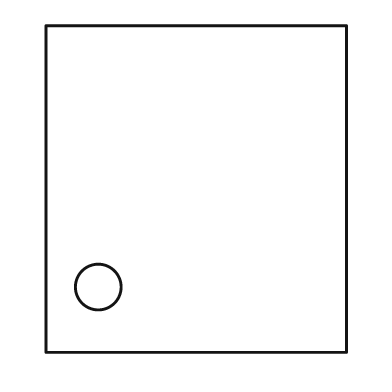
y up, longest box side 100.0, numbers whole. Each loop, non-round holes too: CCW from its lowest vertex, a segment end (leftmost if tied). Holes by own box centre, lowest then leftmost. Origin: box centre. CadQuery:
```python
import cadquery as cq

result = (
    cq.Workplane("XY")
    .moveTo(-46.0, -50.0)
    .lineTo(46.0, -50.0)
    .lineTo(46.0, 50.0)
    .lineTo(-46.0, 50.0)
    .close()
    .moveTo(-30.0, -30.0)
    .circle(7.0)
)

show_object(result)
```